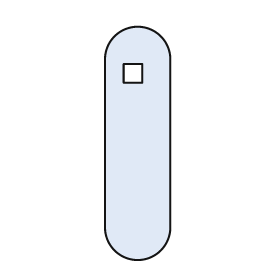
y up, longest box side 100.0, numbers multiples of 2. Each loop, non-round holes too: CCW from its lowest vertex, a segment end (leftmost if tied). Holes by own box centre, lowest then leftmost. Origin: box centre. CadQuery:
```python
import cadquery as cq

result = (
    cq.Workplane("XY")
    .moveTo(-14.0, -36.0)
    .threePointArc((0.0, -50.0), (14.0, -36.0))
    .lineTo(14.0, 36.0)
    .threePointArc((0.0, 50.0), (-14.0, 36.0))
    .close()
    .moveTo(-6.0, 26.0)
    .lineTo(2.0, 26.0)
    .lineTo(2.0, 34.0)
    .lineTo(-6.0, 34.0)
    .close()
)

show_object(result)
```